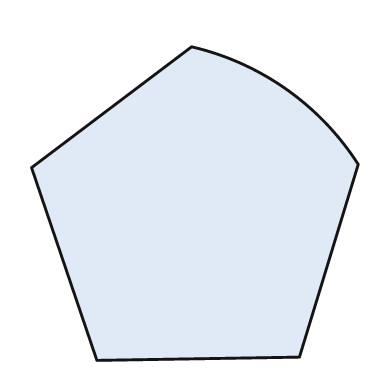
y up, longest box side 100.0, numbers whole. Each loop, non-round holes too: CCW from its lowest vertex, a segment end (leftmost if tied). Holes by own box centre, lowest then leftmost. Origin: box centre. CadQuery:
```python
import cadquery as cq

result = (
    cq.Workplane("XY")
    .moveTo(-30.0, -48.0)
    .lineTo(32.0, -47.0)
    .lineTo(50.0, 12.0)
    .threePointArc((28.0, 35.0), (-1.0, 48.0))
    .lineTo(-50.0, 11.0)
    .close()
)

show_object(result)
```